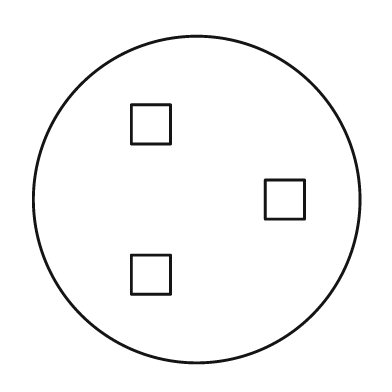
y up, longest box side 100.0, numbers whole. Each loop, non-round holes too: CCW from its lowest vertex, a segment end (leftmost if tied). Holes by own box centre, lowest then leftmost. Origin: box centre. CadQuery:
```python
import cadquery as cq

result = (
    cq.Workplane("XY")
    .moveTo(0.0, 0.0)
    .circle(50.0)
    .moveTo(-20.0, -29.0)
    .lineTo(-8.0, -29.0)
    .lineTo(-8.0, -17.0)
    .lineTo(-20.0, -17.0)
    .close()
    .moveTo(21.0, -6.0)
    .lineTo(33.0, -6.0)
    .lineTo(33.0, 6.0)
    .lineTo(21.0, 6.0)
    .close()
    .moveTo(-20.0, 17.0)
    .lineTo(-8.0, 17.0)
    .lineTo(-8.0, 29.0)
    .lineTo(-20.0, 29.0)
    .close()
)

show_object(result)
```